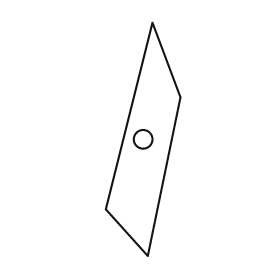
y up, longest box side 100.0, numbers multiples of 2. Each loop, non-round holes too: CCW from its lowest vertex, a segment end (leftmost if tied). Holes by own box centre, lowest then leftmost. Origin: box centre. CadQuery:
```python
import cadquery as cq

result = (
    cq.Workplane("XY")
    .moveTo(2.0, -50.0)
    .lineTo(16.0, 18.0)
    .lineTo(4.0, 50.0)
    .lineTo(-16.0, -30.0)
    .close()
    .moveTo(0.0, 0.0)
    .circle(4.0)
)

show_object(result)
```